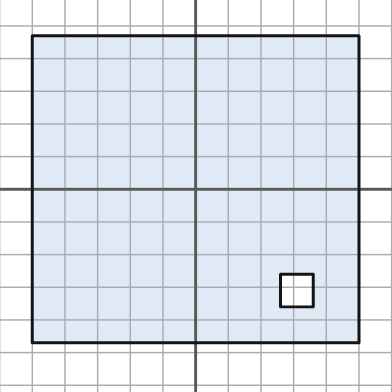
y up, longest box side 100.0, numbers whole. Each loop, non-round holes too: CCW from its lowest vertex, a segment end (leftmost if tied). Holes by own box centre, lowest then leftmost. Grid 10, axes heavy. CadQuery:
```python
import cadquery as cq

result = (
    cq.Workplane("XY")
    .moveTo(-50.0, -47.0)
    .lineTo(50.0, -47.0)
    .lineTo(50.0, 47.0)
    .lineTo(-50.0, 47.0)
    .close()
    .moveTo(26.0, -36.0)
    .lineTo(36.0, -36.0)
    .lineTo(36.0, -26.0)
    .lineTo(26.0, -26.0)
    .close()
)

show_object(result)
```